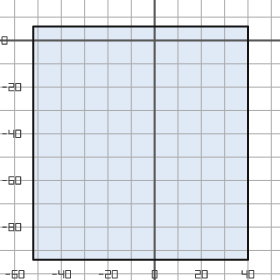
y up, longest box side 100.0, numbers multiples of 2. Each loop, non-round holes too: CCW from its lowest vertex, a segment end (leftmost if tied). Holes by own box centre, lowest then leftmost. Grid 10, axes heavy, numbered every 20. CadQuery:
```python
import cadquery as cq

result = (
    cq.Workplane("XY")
    .moveTo(-52.0, -94.0)
    .lineTo(40.0, -94.0)
    .lineTo(40.0, 6.0)
    .lineTo(-52.0, 6.0)
    .close()
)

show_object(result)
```